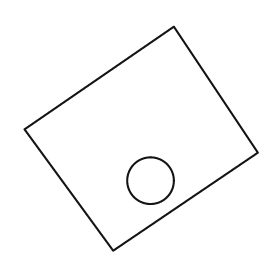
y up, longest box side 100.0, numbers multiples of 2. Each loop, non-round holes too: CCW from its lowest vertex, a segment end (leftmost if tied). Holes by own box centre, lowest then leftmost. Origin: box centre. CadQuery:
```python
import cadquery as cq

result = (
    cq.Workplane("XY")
    .moveTo(-12.0, -48.0)
    .lineTo(50.0, -6.0)
    .lineTo(14.0, 48.0)
    .lineTo(-50.0, 4.0)
    .close()
    .moveTo(4.0, -18.0)
    .circle(10.0)
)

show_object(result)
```